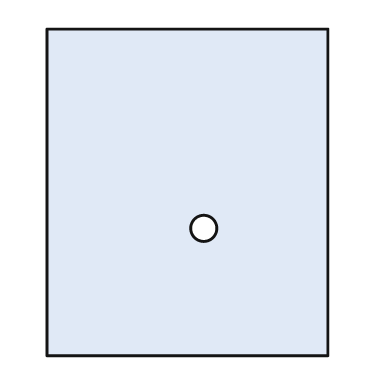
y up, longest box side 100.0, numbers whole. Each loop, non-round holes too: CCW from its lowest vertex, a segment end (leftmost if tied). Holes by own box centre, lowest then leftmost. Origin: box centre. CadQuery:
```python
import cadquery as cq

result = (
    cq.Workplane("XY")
    .moveTo(-43.0, -50.0)
    .lineTo(43.0, -50.0)
    .lineTo(43.0, 50.0)
    .lineTo(-43.0, 50.0)
    .close()
    .moveTo(5.0, -11.0)
    .circle(4.0)
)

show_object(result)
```